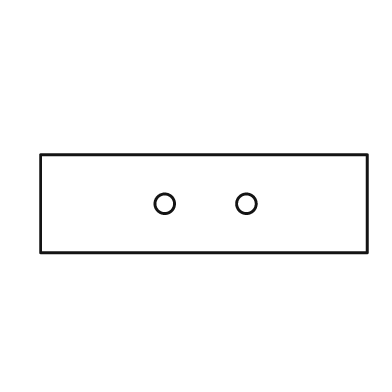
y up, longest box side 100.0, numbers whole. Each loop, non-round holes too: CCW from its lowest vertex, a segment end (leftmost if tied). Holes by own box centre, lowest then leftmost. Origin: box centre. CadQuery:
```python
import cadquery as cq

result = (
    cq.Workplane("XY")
    .moveTo(-50.0, -15.0)
    .lineTo(50.0, -15.0)
    .lineTo(50.0, 15.0)
    .lineTo(-50.0, 15.0)
    .close()
    .moveTo(-12.0, 0.0)
    .circle(3.0)
    .moveTo(13.0, 0.0)
    .circle(3.0)
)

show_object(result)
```